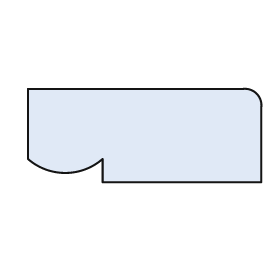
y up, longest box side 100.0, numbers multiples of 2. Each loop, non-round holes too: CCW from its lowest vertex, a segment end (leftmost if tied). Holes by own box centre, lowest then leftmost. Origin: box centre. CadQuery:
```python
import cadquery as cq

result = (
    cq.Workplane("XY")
    .moveTo(-18.0, -20.0)
    .lineTo(50.0, -20.0)
    .lineTo(50.0, 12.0)
    .threePointArc((48.0, 18.0), (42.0, 20.0))
    .lineTo(-50.0, 20.0)
    .lineTo(-50.0, -10.0)
    .threePointArc((-34.0, -16.0), (-18.0, -10.0))
    .close()
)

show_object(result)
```